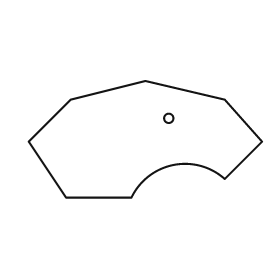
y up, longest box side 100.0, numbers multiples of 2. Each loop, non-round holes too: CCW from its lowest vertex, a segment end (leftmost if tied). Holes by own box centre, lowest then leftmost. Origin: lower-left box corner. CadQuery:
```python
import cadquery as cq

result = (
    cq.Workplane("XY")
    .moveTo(16.0, 0.0)
    .lineTo(44.0, 0.0)
    .threePointArc((62.0, 14.0), (84.0, 8.0))
    .lineTo(100.0, 24.0)
    .lineTo(84.0, 42.0)
    .lineTo(50.0, 50.0)
    .lineTo(18.0, 42.0)
    .lineTo(0.0, 24.0)
    .close()
    .moveTo(60.0, 34.0)
    .circle(2.0)
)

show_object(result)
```